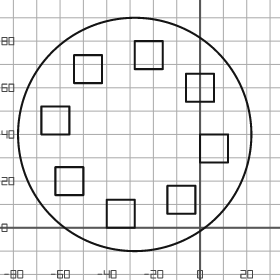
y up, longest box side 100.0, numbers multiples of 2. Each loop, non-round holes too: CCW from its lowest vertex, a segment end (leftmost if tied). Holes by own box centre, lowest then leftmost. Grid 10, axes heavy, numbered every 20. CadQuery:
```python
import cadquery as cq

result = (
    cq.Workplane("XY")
    .moveTo(-28.0, 40.0)
    .circle(50.0)
    .moveTo(-40.0, 0.0)
    .lineTo(-28.0, 0.0)
    .lineTo(-28.0, 12.0)
    .lineTo(-40.0, 12.0)
    .close()
    .moveTo(-14.0, 6.0)
    .lineTo(-2.0, 6.0)
    .lineTo(-2.0, 18.0)
    .lineTo(-14.0, 18.0)
    .close()
    .moveTo(-62.0, 14.0)
    .lineTo(-50.0, 14.0)
    .lineTo(-50.0, 26.0)
    .lineTo(-62.0, 26.0)
    .close()
    .moveTo(0.0, 28.0)
    .lineTo(12.0, 28.0)
    .lineTo(12.0, 40.0)
    .lineTo(0.0, 40.0)
    .close()
    .moveTo(-68.0, 40.0)
    .lineTo(-56.0, 40.0)
    .lineTo(-56.0, 52.0)
    .lineTo(-68.0, 52.0)
    .close()
    .moveTo(-6.0, 54.0)
    .lineTo(6.0, 54.0)
    .lineTo(6.0, 66.0)
    .lineTo(-6.0, 66.0)
    .close()
    .moveTo(-54.0, 62.0)
    .lineTo(-42.0, 62.0)
    .lineTo(-42.0, 74.0)
    .lineTo(-54.0, 74.0)
    .close()
    .moveTo(-28.0, 68.0)
    .lineTo(-16.0, 68.0)
    .lineTo(-16.0, 80.0)
    .lineTo(-28.0, 80.0)
    .close()
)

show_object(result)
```